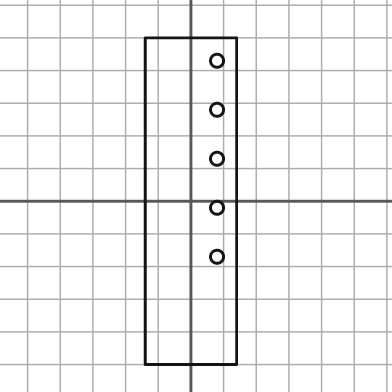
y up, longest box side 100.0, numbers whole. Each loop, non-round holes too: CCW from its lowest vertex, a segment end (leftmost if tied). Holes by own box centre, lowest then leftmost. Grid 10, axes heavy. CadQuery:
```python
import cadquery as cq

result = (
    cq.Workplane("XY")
    .moveTo(-14.0, -50.0)
    .lineTo(14.0, -50.0)
    .lineTo(14.0, 50.0)
    .lineTo(-14.0, 50.0)
    .close()
    .moveTo(8.0, -17.0)
    .circle(2.0)
    .moveTo(8.0, -2.0)
    .circle(2.0)
    .moveTo(8.0, 13.0)
    .circle(2.0)
    .moveTo(8.0, 28.0)
    .circle(2.0)
    .moveTo(8.0, 43.0)
    .circle(2.0)
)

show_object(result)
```